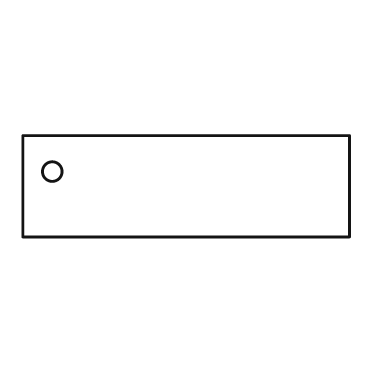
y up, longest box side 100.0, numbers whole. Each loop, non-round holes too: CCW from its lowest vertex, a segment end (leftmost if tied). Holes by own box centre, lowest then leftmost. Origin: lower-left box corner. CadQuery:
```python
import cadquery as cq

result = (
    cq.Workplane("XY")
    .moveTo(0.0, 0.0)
    .lineTo(100.0, 0.0)
    .lineTo(100.0, 31.0)
    .lineTo(0.0, 31.0)
    .close()
    .moveTo(9.0, 20.0)
    .circle(3.0)
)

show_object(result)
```